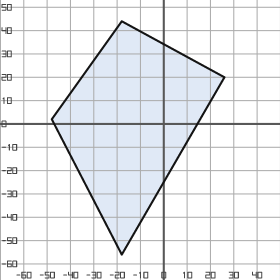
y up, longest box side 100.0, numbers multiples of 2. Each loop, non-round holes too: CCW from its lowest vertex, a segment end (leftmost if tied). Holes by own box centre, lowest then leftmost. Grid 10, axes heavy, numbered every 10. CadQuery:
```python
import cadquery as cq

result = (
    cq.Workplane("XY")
    .moveTo(-18.0, -56.0)
    .lineTo(26.0, 20.0)
    .lineTo(-18.0, 44.0)
    .lineTo(-48.0, 2.0)
    .close()
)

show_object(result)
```